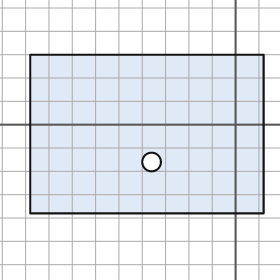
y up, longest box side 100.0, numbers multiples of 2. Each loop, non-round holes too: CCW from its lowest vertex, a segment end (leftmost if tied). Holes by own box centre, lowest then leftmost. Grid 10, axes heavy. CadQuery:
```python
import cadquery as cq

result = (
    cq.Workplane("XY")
    .moveTo(-88.0, -38.0)
    .lineTo(12.0, -38.0)
    .lineTo(12.0, 30.0)
    .lineTo(-88.0, 30.0)
    .close()
    .moveTo(-36.0, -16.0)
    .circle(4.0)
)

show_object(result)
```